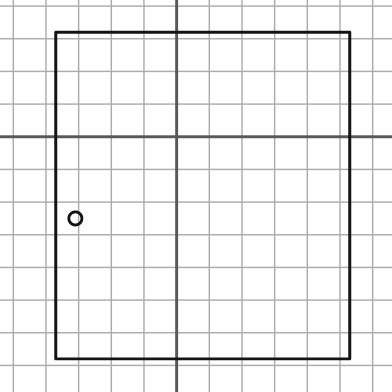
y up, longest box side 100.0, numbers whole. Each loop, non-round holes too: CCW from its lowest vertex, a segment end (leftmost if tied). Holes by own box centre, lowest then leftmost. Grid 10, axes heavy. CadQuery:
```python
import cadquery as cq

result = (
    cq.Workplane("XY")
    .moveTo(-37.0, -68.0)
    .lineTo(53.0, -68.0)
    .lineTo(53.0, 32.0)
    .lineTo(-37.0, 32.0)
    .close()
    .moveTo(-31.0, -25.0)
    .circle(2.0)
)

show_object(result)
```